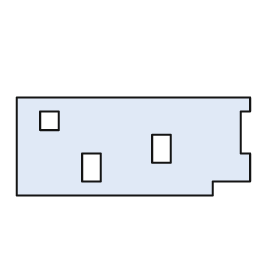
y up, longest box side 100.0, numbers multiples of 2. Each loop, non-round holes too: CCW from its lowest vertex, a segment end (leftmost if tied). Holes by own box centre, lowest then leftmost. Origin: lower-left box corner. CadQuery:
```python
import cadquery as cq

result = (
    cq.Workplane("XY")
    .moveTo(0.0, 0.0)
    .lineTo(84.0, 0.0)
    .lineTo(84.0, 6.0)
    .lineTo(100.0, 6.0)
    .lineTo(100.0, 18.0)
    .lineTo(96.0, 18.0)
    .lineTo(96.0, 36.0)
    .lineTo(100.0, 36.0)
    .lineTo(100.0, 42.0)
    .lineTo(0.0, 42.0)
    .close()
    .moveTo(28.0, 6.0)
    .lineTo(36.0, 6.0)
    .lineTo(36.0, 18.0)
    .lineTo(28.0, 18.0)
    .close()
    .moveTo(58.0, 14.0)
    .lineTo(66.0, 14.0)
    .lineTo(66.0, 26.0)
    .lineTo(58.0, 26.0)
    .close()
    .moveTo(10.0, 28.0)
    .lineTo(18.0, 28.0)
    .lineTo(18.0, 36.0)
    .lineTo(10.0, 36.0)
    .close()
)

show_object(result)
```